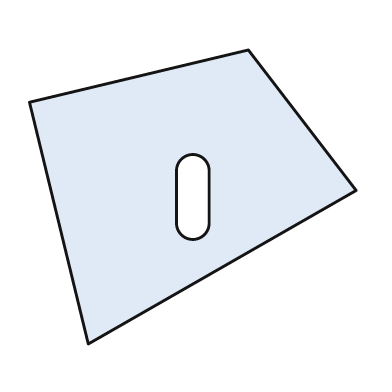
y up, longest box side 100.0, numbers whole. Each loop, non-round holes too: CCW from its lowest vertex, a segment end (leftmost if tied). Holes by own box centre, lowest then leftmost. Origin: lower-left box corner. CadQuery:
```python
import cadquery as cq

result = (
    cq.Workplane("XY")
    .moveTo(18.0, 0.0)
    .lineTo(100.0, 47.0)
    .lineTo(67.0, 90.0)
    .lineTo(0.0, 74.0)
    .close()
    .moveTo(45.0, 37.0)
    .threePointArc((50.0, 32.0), (55.0, 37.0))
    .lineTo(55.0, 53.0)
    .threePointArc((50.0, 58.0), (45.0, 53.0))
    .close()
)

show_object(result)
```